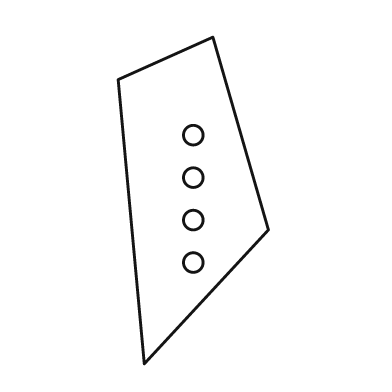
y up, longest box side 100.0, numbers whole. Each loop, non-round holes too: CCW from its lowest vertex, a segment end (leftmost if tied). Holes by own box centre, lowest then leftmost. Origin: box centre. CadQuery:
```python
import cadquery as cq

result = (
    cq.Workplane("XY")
    .moveTo(-15.0, -50.0)
    .lineTo(23.0, -9.0)
    .lineTo(6.0, 50.0)
    .lineTo(-23.0, 37.0)
    .close()
    .moveTo(0.0, -19.0)
    .circle(3.0)
    .moveTo(0.0, -6.0)
    .circle(3.0)
    .moveTo(0.0, 7.0)
    .circle(3.0)
    .moveTo(0.0, 20.0)
    .circle(3.0)
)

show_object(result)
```